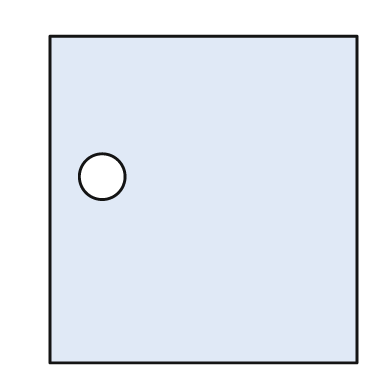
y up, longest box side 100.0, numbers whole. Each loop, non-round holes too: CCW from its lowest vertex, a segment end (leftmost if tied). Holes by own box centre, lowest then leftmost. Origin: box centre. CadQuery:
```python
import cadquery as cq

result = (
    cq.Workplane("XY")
    .moveTo(-47.0, -50.0)
    .lineTo(47.0, -50.0)
    .lineTo(47.0, 50.0)
    .lineTo(-47.0, 50.0)
    .close()
    .moveTo(-31.0, 7.0)
    .circle(7.0)
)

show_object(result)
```